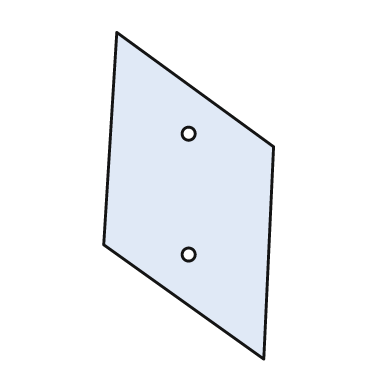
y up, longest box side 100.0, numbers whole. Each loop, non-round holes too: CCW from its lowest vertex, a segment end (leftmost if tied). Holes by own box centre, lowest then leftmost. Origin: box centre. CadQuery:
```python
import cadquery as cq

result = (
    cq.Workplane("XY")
    .moveTo(23.0, -50.0)
    .lineTo(26.0, 15.0)
    .lineTo(-22.0, 50.0)
    .lineTo(-26.0, -15.0)
    .close()
    .moveTo(0.0, -18.0)
    .circle(2.0)
    .moveTo(0.0, 19.0)
    .circle(2.0)
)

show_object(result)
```